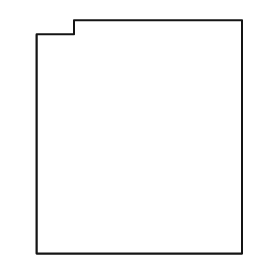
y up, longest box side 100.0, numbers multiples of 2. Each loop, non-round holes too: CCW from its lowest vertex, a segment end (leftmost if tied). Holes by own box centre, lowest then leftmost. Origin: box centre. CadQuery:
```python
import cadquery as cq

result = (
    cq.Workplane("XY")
    .moveTo(-44.0, -50.0)
    .lineTo(44.0, -50.0)
    .lineTo(44.0, 50.0)
    .lineTo(-28.0, 50.0)
    .lineTo(-28.0, 44.0)
    .lineTo(-44.0, 44.0)
    .close()
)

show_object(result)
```